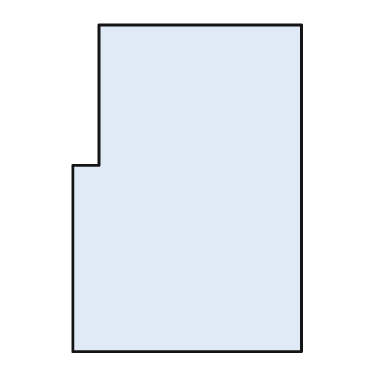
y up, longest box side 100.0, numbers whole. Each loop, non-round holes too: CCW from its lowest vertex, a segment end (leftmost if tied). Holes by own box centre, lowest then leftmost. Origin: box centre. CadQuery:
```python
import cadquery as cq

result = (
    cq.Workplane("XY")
    .moveTo(-35.0, -50.0)
    .lineTo(35.0, -50.0)
    .lineTo(35.0, 50.0)
    .lineTo(-27.0, 50.0)
    .lineTo(-27.0, 7.0)
    .lineTo(-35.0, 7.0)
    .close()
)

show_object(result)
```